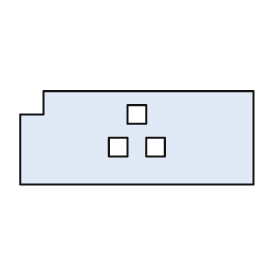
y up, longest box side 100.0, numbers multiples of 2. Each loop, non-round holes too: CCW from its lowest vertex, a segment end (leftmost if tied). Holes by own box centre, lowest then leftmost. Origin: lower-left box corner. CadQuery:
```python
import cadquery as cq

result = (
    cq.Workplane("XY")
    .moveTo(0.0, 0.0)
    .lineTo(100.0, 0.0)
    .lineTo(100.0, 40.0)
    .lineTo(10.0, 40.0)
    .lineTo(10.0, 30.0)
    .lineTo(0.0, 30.0)
    .close()
    .moveTo(38.0, 12.0)
    .lineTo(46.0, 12.0)
    .lineTo(46.0, 20.0)
    .lineTo(38.0, 20.0)
    .close()
    .moveTo(54.0, 12.0)
    .lineTo(62.0, 12.0)
    .lineTo(62.0, 20.0)
    .lineTo(54.0, 20.0)
    .close()
    .moveTo(46.0, 26.0)
    .lineTo(54.0, 26.0)
    .lineTo(54.0, 34.0)
    .lineTo(46.0, 34.0)
    .close()
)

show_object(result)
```